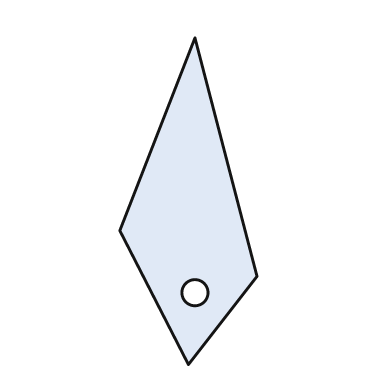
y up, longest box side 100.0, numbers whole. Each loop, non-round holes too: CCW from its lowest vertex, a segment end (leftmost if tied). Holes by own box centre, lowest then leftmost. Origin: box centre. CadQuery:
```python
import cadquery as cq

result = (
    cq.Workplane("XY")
    .moveTo(0.0, -50.0)
    .lineTo(21.0, -23.0)
    .lineTo(2.0, 50.0)
    .lineTo(-21.0, -9.0)
    .close()
    .moveTo(2.0, -28.0)
    .circle(4.0)
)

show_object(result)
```